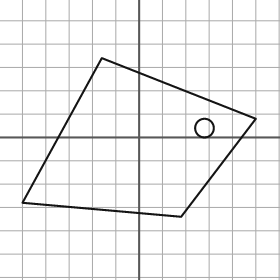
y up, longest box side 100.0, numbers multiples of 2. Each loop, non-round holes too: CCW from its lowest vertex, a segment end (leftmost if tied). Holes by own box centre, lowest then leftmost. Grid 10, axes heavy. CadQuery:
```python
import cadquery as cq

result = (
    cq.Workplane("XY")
    .moveTo(18.0, -34.0)
    .lineTo(50.0, 8.0)
    .lineTo(-16.0, 34.0)
    .lineTo(-50.0, -28.0)
    .close()
    .moveTo(28.0, 4.0)
    .circle(4.0)
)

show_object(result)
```